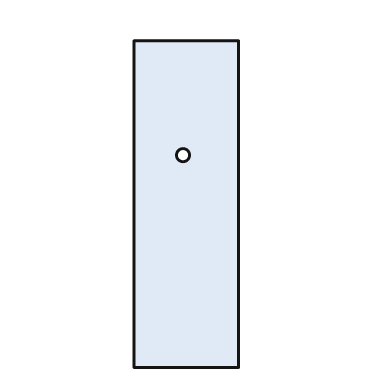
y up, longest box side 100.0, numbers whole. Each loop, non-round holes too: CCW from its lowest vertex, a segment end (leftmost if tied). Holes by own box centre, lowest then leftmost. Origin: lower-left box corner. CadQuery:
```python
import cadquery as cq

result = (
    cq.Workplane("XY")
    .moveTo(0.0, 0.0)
    .lineTo(32.0, 0.0)
    .lineTo(32.0, 100.0)
    .lineTo(0.0, 100.0)
    .close()
    .moveTo(15.0, 65.0)
    .circle(2.0)
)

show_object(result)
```